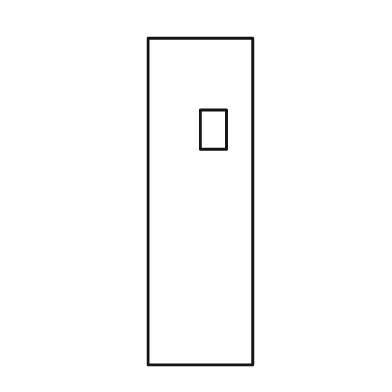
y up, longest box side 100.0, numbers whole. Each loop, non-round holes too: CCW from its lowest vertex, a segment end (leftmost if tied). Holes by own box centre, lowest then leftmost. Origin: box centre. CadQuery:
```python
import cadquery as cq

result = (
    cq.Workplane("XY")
    .moveTo(-16.0, -50.0)
    .lineTo(16.0, -50.0)
    .lineTo(16.0, 50.0)
    .lineTo(-16.0, 50.0)
    .close()
    .moveTo(0.0, 16.0)
    .lineTo(8.0, 16.0)
    .lineTo(8.0, 28.0)
    .lineTo(0.0, 28.0)
    .close()
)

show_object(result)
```